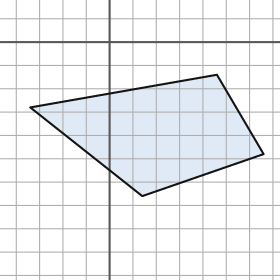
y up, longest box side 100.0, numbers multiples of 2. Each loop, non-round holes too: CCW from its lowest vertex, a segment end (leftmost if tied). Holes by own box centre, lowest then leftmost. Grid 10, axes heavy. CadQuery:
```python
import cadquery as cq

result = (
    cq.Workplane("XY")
    .moveTo(14.0, -66.0)
    .lineTo(66.0, -48.0)
    .lineTo(46.0, -14.0)
    .lineTo(-34.0, -28.0)
    .close()
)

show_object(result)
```